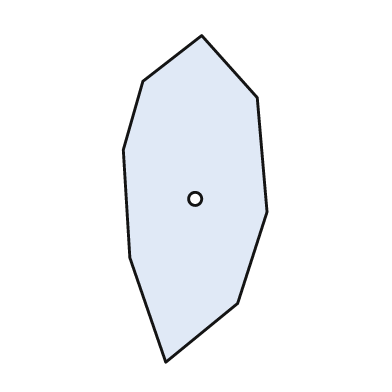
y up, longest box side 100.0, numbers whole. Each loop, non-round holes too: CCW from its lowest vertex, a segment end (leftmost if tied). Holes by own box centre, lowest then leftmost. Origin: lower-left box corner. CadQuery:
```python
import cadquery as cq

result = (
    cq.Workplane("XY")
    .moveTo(13.0, 0.0)
    .lineTo(35.0, 18.0)
    .lineTo(44.0, 46.0)
    .lineTo(41.0, 81.0)
    .lineTo(24.0, 100.0)
    .lineTo(6.0, 86.0)
    .lineTo(0.0, 65.0)
    .lineTo(2.0, 32.0)
    .close()
    .moveTo(22.0, 50.0)
    .circle(2.0)
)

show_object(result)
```